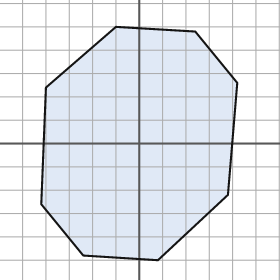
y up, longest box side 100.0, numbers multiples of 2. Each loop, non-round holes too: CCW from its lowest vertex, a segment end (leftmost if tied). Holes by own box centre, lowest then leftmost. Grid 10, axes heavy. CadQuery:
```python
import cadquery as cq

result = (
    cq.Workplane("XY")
    .moveTo(8.0, -50.0)
    .lineTo(38.0, -22.0)
    .lineTo(42.0, 26.0)
    .lineTo(24.0, 48.0)
    .lineTo(-10.0, 50.0)
    .lineTo(-40.0, 24.0)
    .lineTo(-42.0, -26.0)
    .lineTo(-24.0, -48.0)
    .close()
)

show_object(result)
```